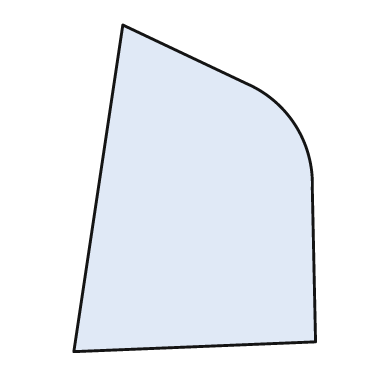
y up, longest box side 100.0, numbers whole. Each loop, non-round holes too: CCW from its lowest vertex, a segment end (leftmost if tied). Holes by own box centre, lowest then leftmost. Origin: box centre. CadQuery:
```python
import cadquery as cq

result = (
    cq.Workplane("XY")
    .moveTo(-37.0, -50.0)
    .lineTo(37.0, -47.0)
    .lineTo(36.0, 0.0)
    .threePointArc((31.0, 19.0), (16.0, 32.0))
    .lineTo(-22.0, 50.0)
    .close()
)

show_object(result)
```